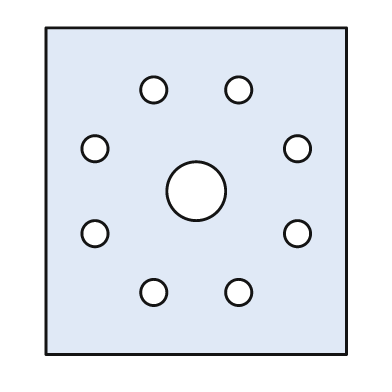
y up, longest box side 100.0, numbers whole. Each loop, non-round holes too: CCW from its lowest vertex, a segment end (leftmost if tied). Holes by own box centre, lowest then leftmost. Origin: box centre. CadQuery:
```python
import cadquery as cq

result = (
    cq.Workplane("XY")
    .moveTo(-46.0, -50.0)
    .lineTo(46.0, -50.0)
    .lineTo(46.0, 50.0)
    .lineTo(-46.0, 50.0)
    .close()
    .moveTo(-13.0, -31.0)
    .circle(4.0)
    .moveTo(13.0, -31.0)
    .circle(4.0)
    .moveTo(-31.0, -13.0)
    .circle(4.0)
    .moveTo(31.0, -13.0)
    .circle(4.0)
    .moveTo(0.0, 0.0)
    .circle(9.0)
    .moveTo(-31.0, 13.0)
    .circle(4.0)
    .moveTo(31.0, 13.0)
    .circle(4.0)
    .moveTo(-13.0, 31.0)
    .circle(4.0)
    .moveTo(13.0, 31.0)
    .circle(4.0)
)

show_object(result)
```